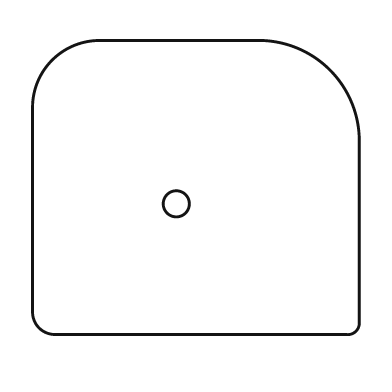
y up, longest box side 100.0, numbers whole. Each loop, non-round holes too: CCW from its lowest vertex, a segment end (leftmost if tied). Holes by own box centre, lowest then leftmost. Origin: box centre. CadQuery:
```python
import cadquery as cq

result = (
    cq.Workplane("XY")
    .moveTo(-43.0, -45.0)
    .lineTo(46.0, -45.0)
    .threePointArc((49.0, -44.0), (50.0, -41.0))
    .lineTo(50.0, 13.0)
    .threePointArc((41.0, 36.0), (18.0, 45.0))
    .lineTo(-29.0, 45.0)
    .threePointArc((-44.0, 39.0), (-50.0, 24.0))
    .lineTo(-50.0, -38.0)
    .threePointArc((-48.0, -43.0), (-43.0, -45.0))
    .close()
    .moveTo(-6.0, -5.0)
    .circle(4.0)
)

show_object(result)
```